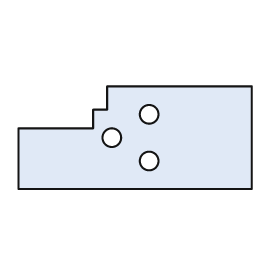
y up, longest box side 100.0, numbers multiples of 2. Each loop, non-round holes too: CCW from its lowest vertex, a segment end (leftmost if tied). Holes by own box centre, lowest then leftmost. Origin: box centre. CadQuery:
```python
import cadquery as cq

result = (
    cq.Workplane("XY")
    .moveTo(-50.0, -22.0)
    .lineTo(50.0, -22.0)
    .lineTo(50.0, 22.0)
    .lineTo(-12.0, 22.0)
    .lineTo(-12.0, 12.0)
    .lineTo(-18.0, 12.0)
    .lineTo(-18.0, 4.0)
    .lineTo(-50.0, 4.0)
    .close()
    .moveTo(6.0, -10.0)
    .circle(4.0)
    .moveTo(-10.0, 0.0)
    .circle(4.0)
    .moveTo(6.0, 10.0)
    .circle(4.0)
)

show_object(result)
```